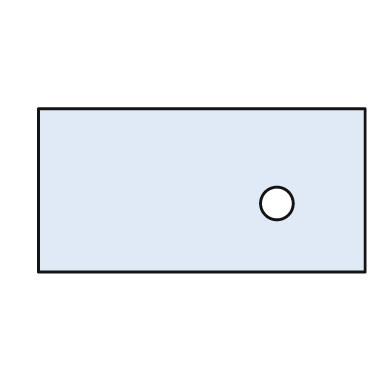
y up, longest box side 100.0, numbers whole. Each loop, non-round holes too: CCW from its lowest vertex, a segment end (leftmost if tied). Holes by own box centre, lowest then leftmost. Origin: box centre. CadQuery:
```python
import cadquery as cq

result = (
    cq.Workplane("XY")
    .moveTo(-50.0, -25.0)
    .lineTo(50.0, -25.0)
    .lineTo(50.0, 25.0)
    .lineTo(-50.0, 25.0)
    .close()
    .moveTo(23.0, -4.0)
    .circle(5.0)
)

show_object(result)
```